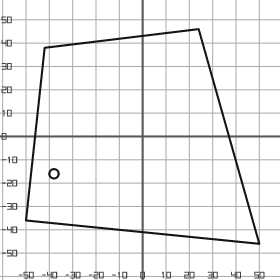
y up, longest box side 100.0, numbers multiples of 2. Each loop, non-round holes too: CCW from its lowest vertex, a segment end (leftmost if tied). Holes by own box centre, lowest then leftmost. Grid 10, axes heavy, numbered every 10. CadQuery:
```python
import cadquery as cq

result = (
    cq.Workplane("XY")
    .moveTo(50.0, -46.0)
    .lineTo(24.0, 46.0)
    .lineTo(-42.0, 38.0)
    .lineTo(-50.0, -36.0)
    .close()
    .moveTo(-38.0, -16.0)
    .circle(2.0)
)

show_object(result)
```